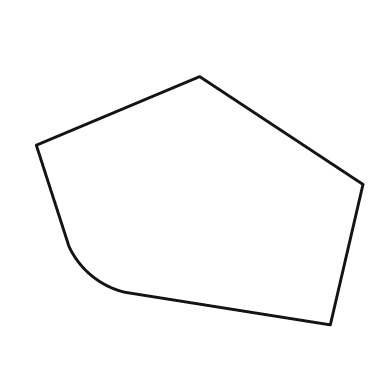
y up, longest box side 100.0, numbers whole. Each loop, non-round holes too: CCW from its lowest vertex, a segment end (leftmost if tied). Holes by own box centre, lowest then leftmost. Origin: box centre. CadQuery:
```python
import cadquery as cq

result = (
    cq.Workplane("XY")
    .moveTo(40.0, -38.0)
    .lineTo(50.0, 5.0)
    .lineTo(0.0, 38.0)
    .lineTo(-50.0, 17.0)
    .lineTo(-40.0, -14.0)
    .threePointArc((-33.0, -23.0), (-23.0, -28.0))
    .close()
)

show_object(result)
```